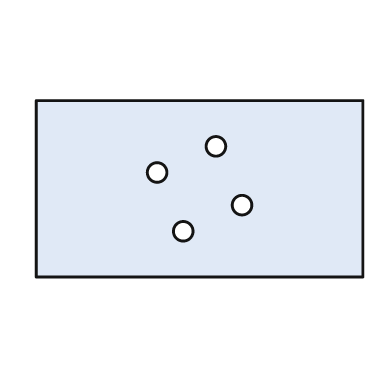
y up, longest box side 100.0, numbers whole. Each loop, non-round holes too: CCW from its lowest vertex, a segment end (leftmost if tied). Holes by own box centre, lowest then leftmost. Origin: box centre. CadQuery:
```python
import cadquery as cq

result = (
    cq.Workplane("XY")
    .moveTo(-50.0, -27.0)
    .lineTo(50.0, -27.0)
    .lineTo(50.0, 27.0)
    .lineTo(-50.0, 27.0)
    .close()
    .moveTo(-5.0, -13.0)
    .circle(3.0)
    .moveTo(13.0, -5.0)
    .circle(3.0)
    .moveTo(-13.0, 5.0)
    .circle(3.0)
    .moveTo(5.0, 13.0)
    .circle(3.0)
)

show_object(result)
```